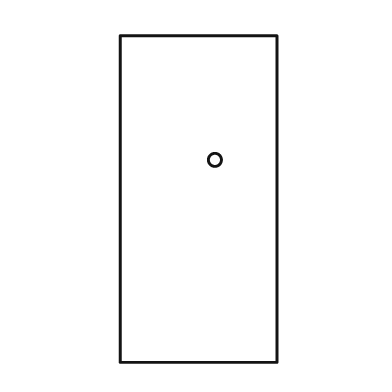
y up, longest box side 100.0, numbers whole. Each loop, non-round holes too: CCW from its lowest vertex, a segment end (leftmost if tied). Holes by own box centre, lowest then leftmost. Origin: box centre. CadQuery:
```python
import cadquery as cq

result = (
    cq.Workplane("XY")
    .moveTo(-24.0, -50.0)
    .lineTo(24.0, -50.0)
    .lineTo(24.0, 50.0)
    .lineTo(-24.0, 50.0)
    .close()
    .moveTo(5.0, 12.0)
    .circle(2.0)
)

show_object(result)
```